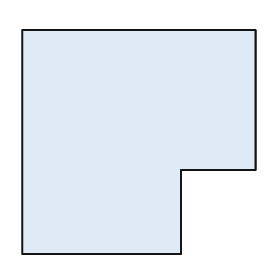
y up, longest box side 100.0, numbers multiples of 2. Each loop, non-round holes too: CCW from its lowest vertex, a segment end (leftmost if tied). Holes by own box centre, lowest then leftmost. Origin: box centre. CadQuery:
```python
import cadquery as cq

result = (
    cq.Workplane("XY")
    .moveTo(-50.0, -48.0)
    .lineTo(18.0, -48.0)
    .lineTo(18.0, -12.0)
    .lineTo(50.0, -12.0)
    .lineTo(50.0, 48.0)
    .lineTo(-50.0, 48.0)
    .close()
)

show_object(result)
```